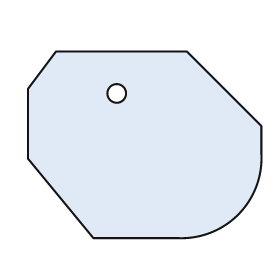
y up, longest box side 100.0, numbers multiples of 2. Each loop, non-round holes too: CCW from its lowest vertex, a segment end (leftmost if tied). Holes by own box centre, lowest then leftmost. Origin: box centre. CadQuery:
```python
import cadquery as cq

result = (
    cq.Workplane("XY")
    .moveTo(-22.0, -40.0)
    .lineTo(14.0, -40.0)
    .threePointArc((40.0, -30.0), (50.0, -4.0))
    .lineTo(50.0, 8.0)
    .lineTo(18.0, 40.0)
    .lineTo(-38.0, 40.0)
    .lineTo(-50.0, 24.0)
    .lineTo(-50.0, -6.0)
    .close()
    .moveTo(-12.0, 22.0)
    .circle(4.0)
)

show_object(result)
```